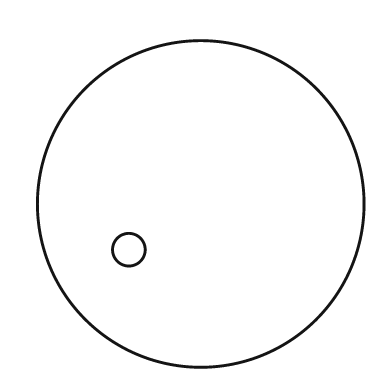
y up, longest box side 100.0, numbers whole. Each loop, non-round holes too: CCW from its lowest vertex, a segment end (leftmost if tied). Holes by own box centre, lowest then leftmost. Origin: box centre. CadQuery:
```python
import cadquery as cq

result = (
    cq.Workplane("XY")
    .moveTo(0.0, 0.0)
    .circle(50.0)
    .moveTo(-22.0, -14.0)
    .circle(5.0)
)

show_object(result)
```